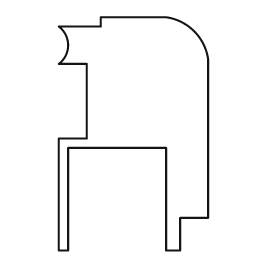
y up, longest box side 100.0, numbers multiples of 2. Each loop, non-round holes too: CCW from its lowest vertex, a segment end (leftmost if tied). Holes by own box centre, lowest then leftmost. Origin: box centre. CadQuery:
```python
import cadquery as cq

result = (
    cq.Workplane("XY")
    .moveTo(-32.0, -50.0)
    .lineTo(-28.0, -50.0)
    .lineTo(-28.0, -6.0)
    .lineTo(14.0, -6.0)
    .lineTo(14.0, -50.0)
    .lineTo(20.0, -50.0)
    .lineTo(20.0, -36.0)
    .lineTo(32.0, -36.0)
    .lineTo(32.0, 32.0)
    .threePointArc((26.0, 44.0), (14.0, 50.0))
    .lineTo(-14.0, 50.0)
    .lineTo(-14.0, 46.0)
    .lineTo(-32.0, 46.0)
    .threePointArc((-28.0, 38.0), (-32.0, 30.0))
    .lineTo(-20.0, 30.0)
    .lineTo(-20.0, -2.0)
    .lineTo(-32.0, -2.0)
    .close()
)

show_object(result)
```